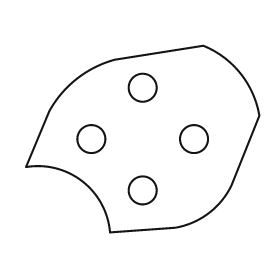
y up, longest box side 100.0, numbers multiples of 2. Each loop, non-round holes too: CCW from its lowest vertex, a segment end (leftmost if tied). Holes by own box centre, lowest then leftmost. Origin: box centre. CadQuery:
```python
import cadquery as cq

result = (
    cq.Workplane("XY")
    .moveTo(-14.0, -40.0)
    .lineTo(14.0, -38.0)
    .threePointArc((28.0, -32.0), (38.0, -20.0))
    .lineTo(50.0, 10.0)
    .threePointArc((42.0, 28.0), (26.0, 40.0))
    .lineTo(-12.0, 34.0)
    .threePointArc((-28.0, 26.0), (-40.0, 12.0))
    .lineTo(-50.0, -12.0)
    .threePointArc((-26.0, -18.0), (-14.0, -40.0))
    .close()
    .moveTo(0.0, -22.0)
    .circle(6.0)
    .moveTo(-22.0, 0.0)
    .circle(6.0)
    .moveTo(22.0, 0.0)
    .circle(6.0)
    .moveTo(0.0, 22.0)
    .circle(6.0)
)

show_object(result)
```